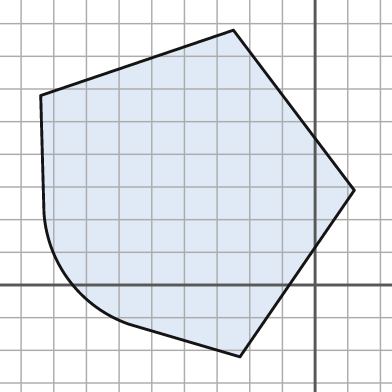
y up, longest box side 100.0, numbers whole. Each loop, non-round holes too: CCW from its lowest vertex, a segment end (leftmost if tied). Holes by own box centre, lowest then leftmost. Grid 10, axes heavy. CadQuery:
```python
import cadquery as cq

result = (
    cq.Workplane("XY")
    .moveTo(-23.0, -22.0)
    .lineTo(12.0, 29.0)
    .lineTo(-25.0, 78.0)
    .lineTo(-84.0, 58.0)
    .lineTo(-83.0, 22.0)
    .threePointArc((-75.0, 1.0), (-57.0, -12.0))
    .close()
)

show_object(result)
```